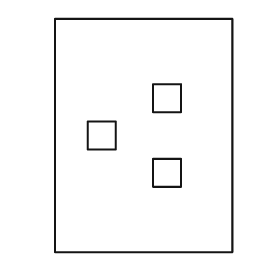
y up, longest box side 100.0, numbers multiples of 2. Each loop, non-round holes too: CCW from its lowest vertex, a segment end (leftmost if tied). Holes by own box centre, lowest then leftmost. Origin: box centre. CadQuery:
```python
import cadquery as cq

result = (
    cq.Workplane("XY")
    .moveTo(-38.0, -50.0)
    .lineTo(38.0, -50.0)
    .lineTo(38.0, 50.0)
    .lineTo(-38.0, 50.0)
    .close()
    .moveTo(4.0, -22.0)
    .lineTo(16.0, -22.0)
    .lineTo(16.0, -10.0)
    .lineTo(4.0, -10.0)
    .close()
    .moveTo(-24.0, -6.0)
    .lineTo(-12.0, -6.0)
    .lineTo(-12.0, 6.0)
    .lineTo(-24.0, 6.0)
    .close()
    .moveTo(4.0, 10.0)
    .lineTo(16.0, 10.0)
    .lineTo(16.0, 22.0)
    .lineTo(4.0, 22.0)
    .close()
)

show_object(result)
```